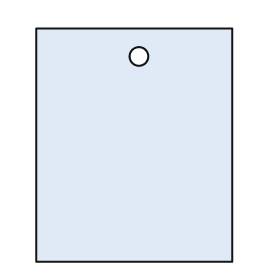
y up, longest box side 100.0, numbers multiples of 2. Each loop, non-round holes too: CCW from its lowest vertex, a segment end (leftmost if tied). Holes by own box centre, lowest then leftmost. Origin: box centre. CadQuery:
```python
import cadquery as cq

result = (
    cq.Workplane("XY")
    .moveTo(-42.0, -50.0)
    .lineTo(42.0, -50.0)
    .lineTo(42.0, 50.0)
    .lineTo(-42.0, 50.0)
    .close()
    .moveTo(2.0, 38.0)
    .circle(4.0)
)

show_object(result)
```